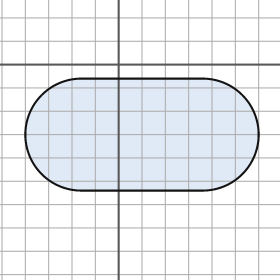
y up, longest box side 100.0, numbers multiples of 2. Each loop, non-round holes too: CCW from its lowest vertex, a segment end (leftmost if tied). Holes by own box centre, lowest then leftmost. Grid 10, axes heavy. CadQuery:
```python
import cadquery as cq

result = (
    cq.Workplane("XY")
    .moveTo(-16.0, -54.0)
    .lineTo(36.0, -54.0)
    .threePointArc((60.0, -30.0), (36.0, -6.0))
    .lineTo(-16.0, -6.0)
    .threePointArc((-40.0, -30.0), (-16.0, -54.0))
    .close()
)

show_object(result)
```